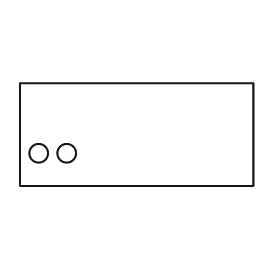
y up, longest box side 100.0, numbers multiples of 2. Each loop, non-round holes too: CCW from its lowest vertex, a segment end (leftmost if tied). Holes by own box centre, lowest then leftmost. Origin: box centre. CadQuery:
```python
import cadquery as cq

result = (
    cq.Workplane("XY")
    .moveTo(-50.0, -22.0)
    .lineTo(50.0, -22.0)
    .lineTo(50.0, 22.0)
    .lineTo(-50.0, 22.0)
    .close()
    .moveTo(-42.0, -8.0)
    .circle(4.0)
    .moveTo(-30.0, -8.0)
    .circle(4.0)
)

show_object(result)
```